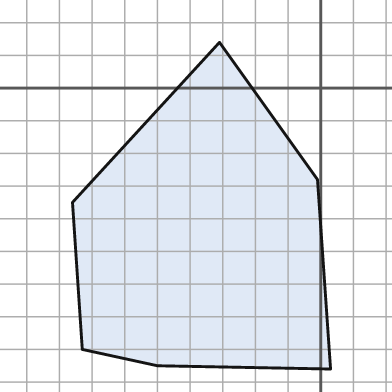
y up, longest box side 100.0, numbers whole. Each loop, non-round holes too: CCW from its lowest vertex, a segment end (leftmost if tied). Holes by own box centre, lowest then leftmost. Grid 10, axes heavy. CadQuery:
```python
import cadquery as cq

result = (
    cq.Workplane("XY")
    .moveTo(3.0, -86.0)
    .lineTo(-1.0, -28.0)
    .lineTo(-31.0, 14.0)
    .lineTo(-76.0, -35.0)
    .lineTo(-73.0, -80.0)
    .lineTo(-50.0, -85.0)
    .close()
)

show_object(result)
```